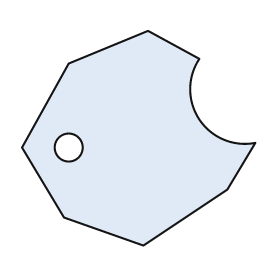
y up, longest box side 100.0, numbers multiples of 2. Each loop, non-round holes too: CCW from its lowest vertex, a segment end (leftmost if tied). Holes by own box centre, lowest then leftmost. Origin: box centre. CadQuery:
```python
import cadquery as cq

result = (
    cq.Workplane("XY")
    .moveTo(2.0, -46.0)
    .lineTo(38.0, -22.0)
    .lineTo(50.0, -2.0)
    .threePointArc((26.0, 8.0), (26.0, 34.0))
    .lineTo(4.0, 46.0)
    .lineTo(-30.0, 32.0)
    .lineTo(-50.0, -4.0)
    .lineTo(-32.0, -34.0)
    .close()
    .moveTo(-30.0, -4.0)
    .circle(6.0)
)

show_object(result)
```